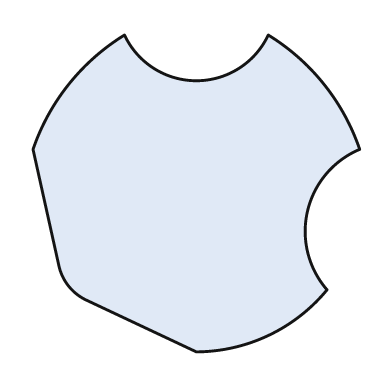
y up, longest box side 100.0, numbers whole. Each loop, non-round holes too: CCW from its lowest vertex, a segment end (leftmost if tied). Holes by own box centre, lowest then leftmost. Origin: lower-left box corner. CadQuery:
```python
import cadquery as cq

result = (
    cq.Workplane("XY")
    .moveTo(50.0, 0.0)
    .threePointArc((72.0, 5.0), (90.0, 19.0))
    .threePointArc((84.0, 43.0), (100.0, 62.0))
    .threePointArc((89.0, 82.0), (72.0, 97.0))
    .threePointArc((50.0, 83.0), (28.0, 97.0))
    .threePointArc((11.0, 82.0), (0.0, 62.0))
    .lineTo(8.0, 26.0)
    .threePointArc((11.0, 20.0), (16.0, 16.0))
    .close()
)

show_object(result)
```